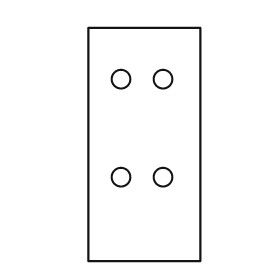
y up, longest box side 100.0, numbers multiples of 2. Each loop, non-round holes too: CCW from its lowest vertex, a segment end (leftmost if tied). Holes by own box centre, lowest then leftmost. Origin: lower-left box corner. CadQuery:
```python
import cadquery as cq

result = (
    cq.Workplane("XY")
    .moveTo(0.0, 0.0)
    .lineTo(48.0, 0.0)
    .lineTo(48.0, 100.0)
    .lineTo(0.0, 100.0)
    .close()
    .moveTo(14.0, 36.0)
    .circle(4.0)
    .moveTo(32.0, 36.0)
    .circle(4.0)
    .moveTo(14.0, 78.0)
    .circle(4.0)
    .moveTo(32.0, 78.0)
    .circle(4.0)
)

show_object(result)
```